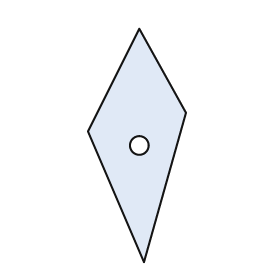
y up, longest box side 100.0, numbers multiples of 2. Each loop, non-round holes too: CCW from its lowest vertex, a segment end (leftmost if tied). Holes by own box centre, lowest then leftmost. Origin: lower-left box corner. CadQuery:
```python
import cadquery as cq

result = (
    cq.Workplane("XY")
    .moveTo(24.0, 0.0)
    .lineTo(42.0, 64.0)
    .lineTo(22.0, 100.0)
    .lineTo(0.0, 56.0)
    .close()
    .moveTo(22.0, 50.0)
    .circle(4.0)
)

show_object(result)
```